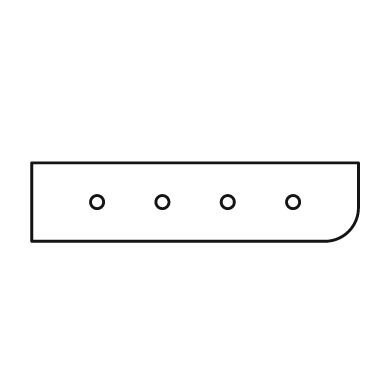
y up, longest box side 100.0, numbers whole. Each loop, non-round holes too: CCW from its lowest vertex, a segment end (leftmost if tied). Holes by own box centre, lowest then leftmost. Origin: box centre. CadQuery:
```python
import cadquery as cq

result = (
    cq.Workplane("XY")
    .moveTo(-50.0, -12.0)
    .lineTo(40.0, -12.0)
    .threePointArc((47.0, -9.0), (50.0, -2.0))
    .lineTo(50.0, 12.0)
    .lineTo(-50.0, 12.0)
    .close()
    .moveTo(-30.0, 0.0)
    .circle(2.0)
    .moveTo(-10.0, 0.0)
    .circle(2.0)
    .moveTo(10.0, 0.0)
    .circle(2.0)
    .moveTo(30.0, 0.0)
    .circle(2.0)
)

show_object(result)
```